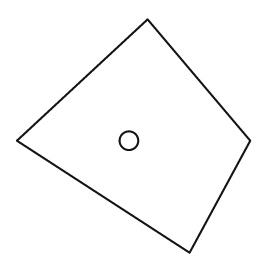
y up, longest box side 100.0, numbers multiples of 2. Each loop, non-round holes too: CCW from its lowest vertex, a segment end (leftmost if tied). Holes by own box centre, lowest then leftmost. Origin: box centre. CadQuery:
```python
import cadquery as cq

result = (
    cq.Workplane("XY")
    .moveTo(24.0, -50.0)
    .lineTo(50.0, -2.0)
    .lineTo(6.0, 50.0)
    .lineTo(-50.0, -2.0)
    .close()
    .moveTo(-2.0, -2.0)
    .circle(4.0)
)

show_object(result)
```